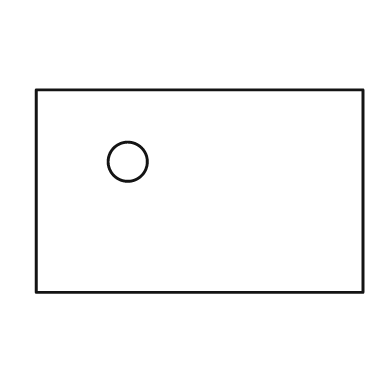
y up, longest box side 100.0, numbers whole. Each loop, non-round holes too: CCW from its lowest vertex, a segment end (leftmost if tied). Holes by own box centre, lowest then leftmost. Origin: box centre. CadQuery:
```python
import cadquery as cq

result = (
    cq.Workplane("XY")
    .moveTo(-50.0, -31.0)
    .lineTo(50.0, -31.0)
    .lineTo(50.0, 31.0)
    .lineTo(-50.0, 31.0)
    .close()
    .moveTo(-22.0, 9.0)
    .circle(6.0)
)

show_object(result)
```